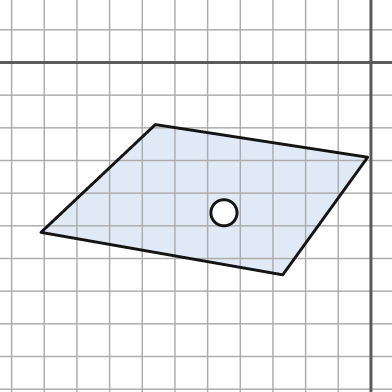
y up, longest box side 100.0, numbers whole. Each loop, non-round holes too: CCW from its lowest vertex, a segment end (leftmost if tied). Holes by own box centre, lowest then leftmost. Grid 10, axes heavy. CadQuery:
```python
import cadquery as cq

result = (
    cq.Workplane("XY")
    .moveTo(-27.0, -65.0)
    .lineTo(-1.0, -29.0)
    .lineTo(-66.0, -19.0)
    .lineTo(-101.0, -52.0)
    .close()
    .moveTo(-45.0, -46.0)
    .circle(4.0)
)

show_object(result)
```